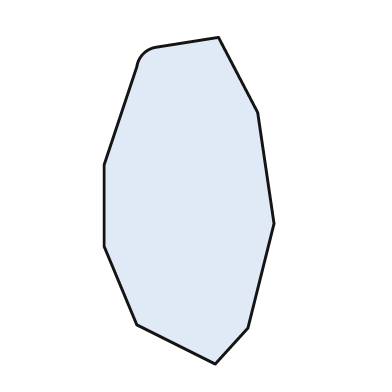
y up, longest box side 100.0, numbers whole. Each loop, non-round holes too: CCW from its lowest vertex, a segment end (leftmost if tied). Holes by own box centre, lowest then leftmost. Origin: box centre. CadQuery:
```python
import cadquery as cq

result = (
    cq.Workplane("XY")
    .moveTo(8.0, -50.0)
    .lineTo(18.0, -39.0)
    .lineTo(26.0, -7.0)
    .lineTo(21.0, 27.0)
    .lineTo(9.0, 50.0)
    .lineTo(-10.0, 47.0)
    .threePointArc((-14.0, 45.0), (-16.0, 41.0))
    .lineTo(-26.0, 11.0)
    .lineTo(-26.0, -14.0)
    .lineTo(-16.0, -38.0)
    .close()
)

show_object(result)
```